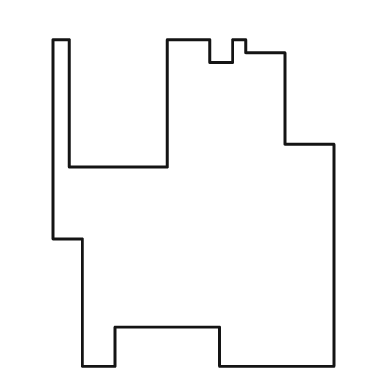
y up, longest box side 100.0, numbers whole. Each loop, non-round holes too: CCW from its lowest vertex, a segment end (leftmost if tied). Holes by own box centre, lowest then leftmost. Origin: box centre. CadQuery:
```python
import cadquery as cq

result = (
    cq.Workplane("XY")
    .moveTo(-34.0, -50.0)
    .lineTo(-24.0, -50.0)
    .lineTo(-24.0, -38.0)
    .lineTo(8.0, -38.0)
    .lineTo(8.0, -50.0)
    .lineTo(43.0, -50.0)
    .lineTo(43.0, 18.0)
    .lineTo(28.0, 18.0)
    .lineTo(28.0, 46.0)
    .lineTo(16.0, 46.0)
    .lineTo(16.0, 50.0)
    .lineTo(12.0, 50.0)
    .lineTo(12.0, 43.0)
    .lineTo(5.0, 43.0)
    .lineTo(5.0, 50.0)
    .lineTo(-8.0, 50.0)
    .lineTo(-8.0, 11.0)
    .lineTo(-38.0, 11.0)
    .lineTo(-38.0, 50.0)
    .lineTo(-43.0, 50.0)
    .lineTo(-43.0, -11.0)
    .lineTo(-34.0, -11.0)
    .close()
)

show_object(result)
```